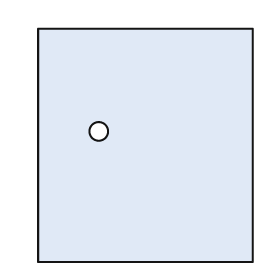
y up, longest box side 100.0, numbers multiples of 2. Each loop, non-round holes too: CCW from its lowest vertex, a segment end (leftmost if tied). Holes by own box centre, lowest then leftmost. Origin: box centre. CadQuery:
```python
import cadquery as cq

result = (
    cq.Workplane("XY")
    .moveTo(-46.0, -50.0)
    .lineTo(46.0, -50.0)
    .lineTo(46.0, 50.0)
    .lineTo(-46.0, 50.0)
    .close()
    .moveTo(-20.0, 6.0)
    .circle(4.0)
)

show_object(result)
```